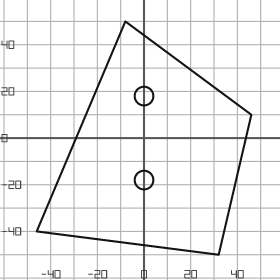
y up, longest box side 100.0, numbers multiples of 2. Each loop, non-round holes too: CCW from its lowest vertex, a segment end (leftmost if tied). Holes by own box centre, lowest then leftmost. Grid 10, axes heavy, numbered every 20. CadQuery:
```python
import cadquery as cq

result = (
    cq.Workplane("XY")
    .moveTo(32.0, -50.0)
    .lineTo(46.0, 10.0)
    .lineTo(-8.0, 50.0)
    .lineTo(-46.0, -40.0)
    .close()
    .moveTo(0.0, -18.0)
    .circle(4.0)
    .moveTo(0.0, 18.0)
    .circle(4.0)
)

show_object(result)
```